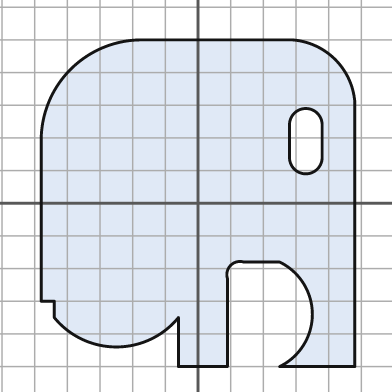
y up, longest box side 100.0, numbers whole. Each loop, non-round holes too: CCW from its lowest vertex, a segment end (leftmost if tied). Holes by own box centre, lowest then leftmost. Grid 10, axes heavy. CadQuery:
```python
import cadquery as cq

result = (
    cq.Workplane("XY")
    .moveTo(-6.0, -50.0)
    .lineTo(9.0, -50.0)
    .lineTo(9.0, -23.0)
    .threePointArc((10.0, -19.0), (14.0, -18.0))
    .lineTo(25.0, -18.0)
    .threePointArc((35.0, -34.0), (25.0, -50.0))
    .lineTo(48.0, -50.0)
    .lineTo(48.0, 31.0)
    .threePointArc((42.0, 44.0), (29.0, 50.0))
    .lineTo(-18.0, 50.0)
    .threePointArc((-39.0, 41.0), (-48.0, 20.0))
    .lineTo(-48.0, -30.0)
    .lineTo(-44.0, -30.0)
    .lineTo(-44.0, -35.0)
    .threePointArc((-25.0, -44.0), (-6.0, -35.0))
    .close()
    .moveTo(28.0, 14.0)
    .threePointArc((33.0, 9.0), (38.0, 14.0))
    .lineTo(38.0, 24.0)
    .threePointArc((33.0, 29.0), (28.0, 24.0))
    .close()
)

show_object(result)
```